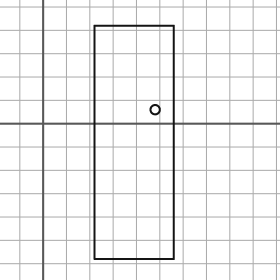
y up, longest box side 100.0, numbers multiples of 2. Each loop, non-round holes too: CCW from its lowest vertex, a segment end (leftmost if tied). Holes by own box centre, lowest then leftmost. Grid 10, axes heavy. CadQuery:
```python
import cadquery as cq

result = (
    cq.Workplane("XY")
    .moveTo(22.0, -58.0)
    .lineTo(56.0, -58.0)
    .lineTo(56.0, 42.0)
    .lineTo(22.0, 42.0)
    .close()
    .moveTo(48.0, 6.0)
    .circle(2.0)
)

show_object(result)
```